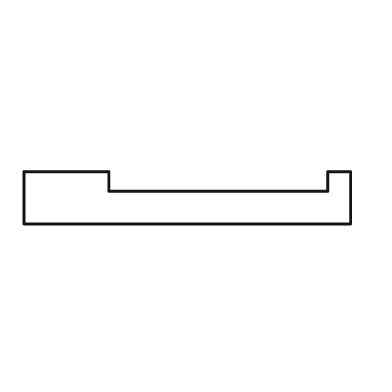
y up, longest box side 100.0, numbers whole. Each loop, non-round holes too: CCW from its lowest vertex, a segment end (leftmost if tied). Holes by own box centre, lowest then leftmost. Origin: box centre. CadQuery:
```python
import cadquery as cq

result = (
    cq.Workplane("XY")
    .moveTo(-50.0, -8.0)
    .lineTo(50.0, -8.0)
    .lineTo(50.0, 8.0)
    .lineTo(43.0, 8.0)
    .lineTo(43.0, 2.0)
    .lineTo(-24.0, 2.0)
    .lineTo(-24.0, 8.0)
    .lineTo(-50.0, 8.0)
    .close()
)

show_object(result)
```